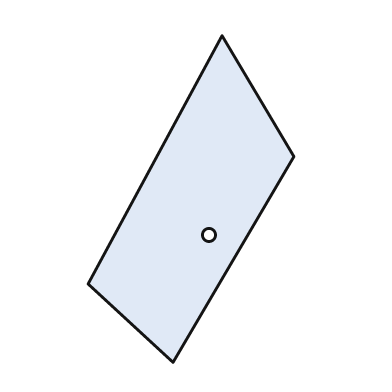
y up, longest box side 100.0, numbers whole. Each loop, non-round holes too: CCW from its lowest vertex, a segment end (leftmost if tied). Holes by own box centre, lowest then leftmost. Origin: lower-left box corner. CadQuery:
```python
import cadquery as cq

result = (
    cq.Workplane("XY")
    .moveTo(26.0, 0.0)
    .lineTo(63.0, 63.0)
    .lineTo(41.0, 100.0)
    .lineTo(0.0, 24.0)
    .close()
    .moveTo(37.0, 39.0)
    .circle(2.0)
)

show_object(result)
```